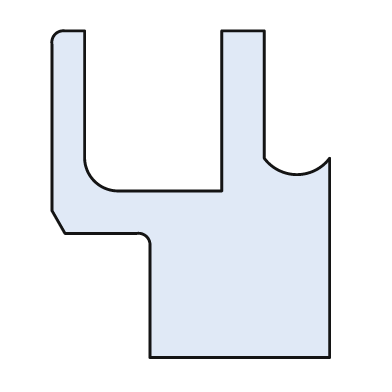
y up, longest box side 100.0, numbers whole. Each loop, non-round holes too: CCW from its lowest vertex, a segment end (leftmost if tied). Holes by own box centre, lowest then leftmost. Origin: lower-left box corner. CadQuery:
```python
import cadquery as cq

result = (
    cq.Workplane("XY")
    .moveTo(30.0, 0.0)
    .lineTo(85.0, 0.0)
    .lineTo(85.0, 61.0)
    .threePointArc((75.0, 56.0), (65.0, 61.0))
    .lineTo(65.0, 100.0)
    .lineTo(52.0, 100.0)
    .lineTo(52.0, 51.0)
    .lineTo(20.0, 51.0)
    .threePointArc((13.0, 54.0), (10.0, 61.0))
    .lineTo(10.0, 100.0)
    .lineTo(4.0, 100.0)
    .threePointArc((1.0, 99.0), (0.0, 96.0))
    .lineTo(0.0, 45.0)
    .lineTo(4.0, 38.0)
    .lineTo(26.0, 38.0)
    .threePointArc((29.0, 37.0), (30.0, 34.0))
    .close()
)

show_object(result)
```